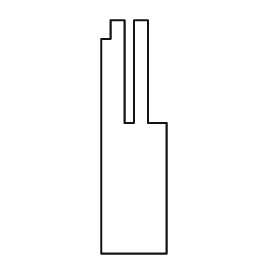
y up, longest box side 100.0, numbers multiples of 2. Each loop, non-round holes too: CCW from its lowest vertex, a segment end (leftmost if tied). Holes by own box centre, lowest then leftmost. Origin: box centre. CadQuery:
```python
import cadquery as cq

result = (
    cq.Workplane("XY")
    .moveTo(-14.0, -50.0)
    .lineTo(14.0, -50.0)
    .lineTo(14.0, 6.0)
    .lineTo(6.0, 6.0)
    .lineTo(6.0, 50.0)
    .lineTo(0.0, 50.0)
    .lineTo(0.0, 6.0)
    .lineTo(-4.0, 6.0)
    .lineTo(-4.0, 50.0)
    .lineTo(-10.0, 50.0)
    .lineTo(-10.0, 42.0)
    .lineTo(-14.0, 42.0)
    .close()
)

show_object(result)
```